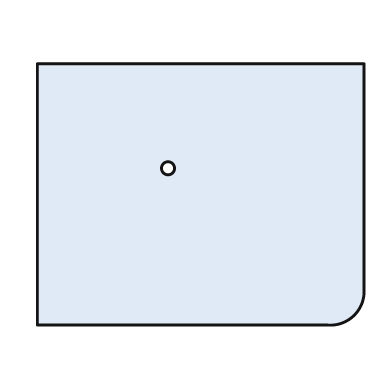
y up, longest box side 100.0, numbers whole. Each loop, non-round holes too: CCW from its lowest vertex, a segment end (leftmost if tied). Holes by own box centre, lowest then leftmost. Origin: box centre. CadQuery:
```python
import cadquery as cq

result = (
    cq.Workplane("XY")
    .moveTo(-50.0, -40.0)
    .lineTo(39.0, -40.0)
    .threePointArc((47.0, -37.0), (50.0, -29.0))
    .lineTo(50.0, 40.0)
    .lineTo(-50.0, 40.0)
    .close()
    .moveTo(-10.0, 8.0)
    .circle(2.0)
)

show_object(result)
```